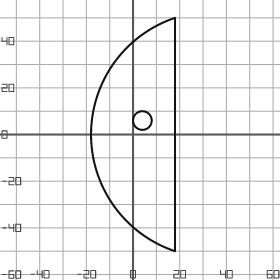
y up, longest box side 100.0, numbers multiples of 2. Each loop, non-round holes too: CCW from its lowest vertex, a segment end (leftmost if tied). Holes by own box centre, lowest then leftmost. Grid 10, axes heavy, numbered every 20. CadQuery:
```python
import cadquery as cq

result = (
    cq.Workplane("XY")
    .moveTo(18.0, -50.0)
    .lineTo(18.0, 50.0)
    .threePointArc((-18.0, 0.0), (18.0, -50.0))
    .close()
    .moveTo(4.0, 6.0)
    .circle(4.0)
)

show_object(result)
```